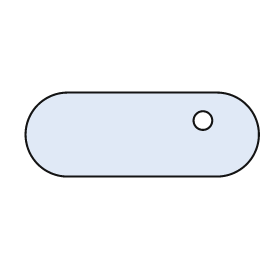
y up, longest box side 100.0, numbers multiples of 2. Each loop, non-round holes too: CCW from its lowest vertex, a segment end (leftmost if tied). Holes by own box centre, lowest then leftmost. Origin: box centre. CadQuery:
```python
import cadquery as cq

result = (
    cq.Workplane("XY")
    .moveTo(-32.0, -18.0)
    .lineTo(32.0, -18.0)
    .threePointArc((50.0, 0.0), (32.0, 18.0))
    .lineTo(-32.0, 18.0)
    .threePointArc((-50.0, 0.0), (-32.0, -18.0))
    .close()
    .moveTo(26.0, 6.0)
    .circle(4.0)
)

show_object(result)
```